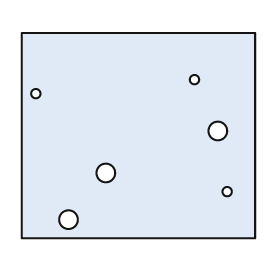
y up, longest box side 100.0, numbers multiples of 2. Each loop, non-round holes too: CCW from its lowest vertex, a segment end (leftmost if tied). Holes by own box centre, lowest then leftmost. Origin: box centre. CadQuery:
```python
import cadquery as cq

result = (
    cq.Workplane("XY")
    .moveTo(-50.0, -44.0)
    .lineTo(50.0, -44.0)
    .lineTo(50.0, 44.0)
    .lineTo(-50.0, 44.0)
    .close()
    .moveTo(-30.0, -36.0)
    .circle(4.0)
    .moveTo(38.0, -24.0)
    .circle(2.0)
    .moveTo(-14.0, -16.0)
    .circle(4.0)
    .moveTo(34.0, 2.0)
    .circle(4.0)
    .moveTo(-44.0, 18.0)
    .circle(2.0)
    .moveTo(24.0, 24.0)
    .circle(2.0)
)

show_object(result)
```